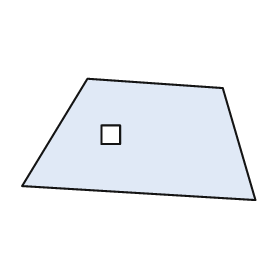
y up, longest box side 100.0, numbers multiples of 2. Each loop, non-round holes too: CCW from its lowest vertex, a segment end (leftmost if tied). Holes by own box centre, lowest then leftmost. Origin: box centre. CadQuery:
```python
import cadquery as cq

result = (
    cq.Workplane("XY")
    .moveTo(50.0, -26.0)
    .lineTo(36.0, 22.0)
    .lineTo(-22.0, 26.0)
    .lineTo(-50.0, -20.0)
    .close()
    .moveTo(-16.0, -2.0)
    .lineTo(-8.0, -2.0)
    .lineTo(-8.0, 6.0)
    .lineTo(-16.0, 6.0)
    .close()
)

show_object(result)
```